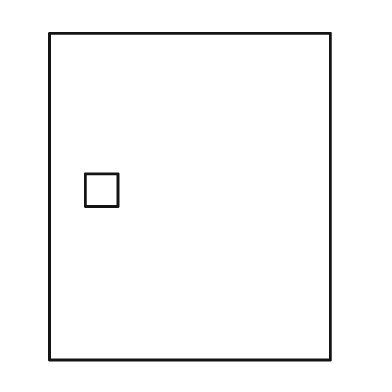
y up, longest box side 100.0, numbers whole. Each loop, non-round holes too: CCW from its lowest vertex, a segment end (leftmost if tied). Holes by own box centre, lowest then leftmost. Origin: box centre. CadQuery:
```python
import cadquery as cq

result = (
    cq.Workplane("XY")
    .moveTo(-43.0, -50.0)
    .lineTo(43.0, -50.0)
    .lineTo(43.0, 50.0)
    .lineTo(-43.0, 50.0)
    .close()
    .moveTo(-32.0, -3.0)
    .lineTo(-22.0, -3.0)
    .lineTo(-22.0, 7.0)
    .lineTo(-32.0, 7.0)
    .close()
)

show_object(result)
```